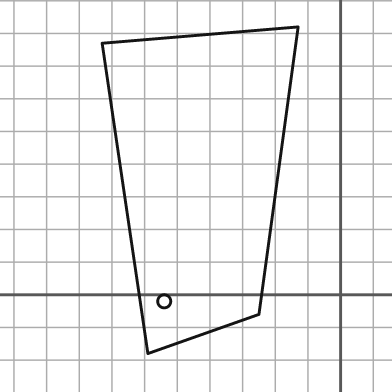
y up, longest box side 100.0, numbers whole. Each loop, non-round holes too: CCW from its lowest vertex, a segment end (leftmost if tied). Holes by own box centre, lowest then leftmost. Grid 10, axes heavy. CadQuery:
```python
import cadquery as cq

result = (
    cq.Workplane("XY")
    .moveTo(-59.0, -18.0)
    .lineTo(-25.0, -6.0)
    .lineTo(-13.0, 82.0)
    .lineTo(-73.0, 77.0)
    .close()
    .moveTo(-54.0, -2.0)
    .circle(2.0)
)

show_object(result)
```